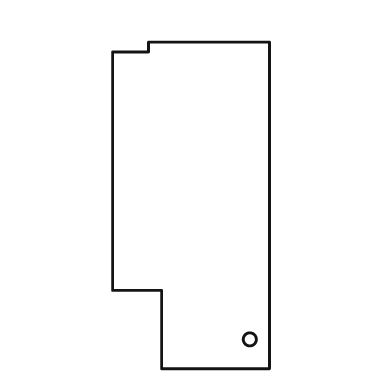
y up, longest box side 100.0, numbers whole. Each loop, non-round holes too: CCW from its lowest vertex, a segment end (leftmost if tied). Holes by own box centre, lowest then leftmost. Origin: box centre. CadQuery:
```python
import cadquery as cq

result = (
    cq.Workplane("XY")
    .moveTo(-9.0, -50.0)
    .lineTo(24.0, -50.0)
    .lineTo(24.0, 50.0)
    .lineTo(-13.0, 50.0)
    .lineTo(-13.0, 47.0)
    .lineTo(-24.0, 47.0)
    .lineTo(-24.0, -26.0)
    .lineTo(-9.0, -26.0)
    .close()
    .moveTo(18.0, -41.0)
    .circle(2.0)
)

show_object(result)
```